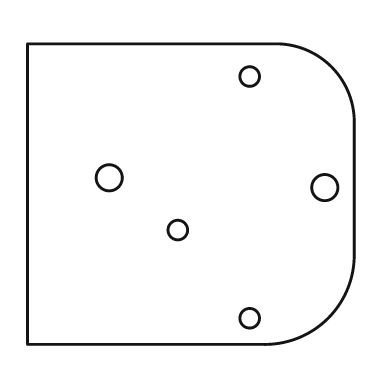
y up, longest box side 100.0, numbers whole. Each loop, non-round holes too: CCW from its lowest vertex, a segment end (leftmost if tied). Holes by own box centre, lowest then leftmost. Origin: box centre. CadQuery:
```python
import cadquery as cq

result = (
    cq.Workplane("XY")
    .moveTo(-50.0, -46.0)
    .lineTo(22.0, -46.0)
    .threePointArc((42.0, -38.0), (50.0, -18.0))
    .lineTo(50.0, 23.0)
    .threePointArc((43.0, 39.0), (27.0, 46.0))
    .lineTo(-50.0, 46.0)
    .close()
    .moveTo(18.0, -38.0)
    .circle(3.0)
    .moveTo(-4.0, -11.0)
    .circle(3.0)
    .moveTo(41.0, 2.0)
    .circle(4.0)
    .moveTo(-25.0, 5.0)
    .circle(4.0)
    .moveTo(18.0, 36.0)
    .circle(3.0)
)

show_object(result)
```